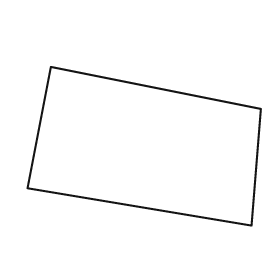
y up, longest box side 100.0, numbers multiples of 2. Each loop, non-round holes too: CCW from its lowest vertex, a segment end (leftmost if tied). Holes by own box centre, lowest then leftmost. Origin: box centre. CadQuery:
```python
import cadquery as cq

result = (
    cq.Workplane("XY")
    .moveTo(46.0, -34.0)
    .lineTo(50.0, 16.0)
    .lineTo(-40.0, 34.0)
    .lineTo(-50.0, -18.0)
    .close()
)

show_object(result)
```